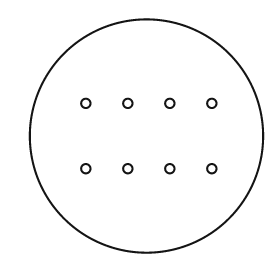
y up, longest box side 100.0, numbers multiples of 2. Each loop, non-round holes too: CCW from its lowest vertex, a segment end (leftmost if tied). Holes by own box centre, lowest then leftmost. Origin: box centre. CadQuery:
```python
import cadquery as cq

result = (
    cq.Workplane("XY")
    .moveTo(0.0, 0.0)
    .circle(50.0)
    .moveTo(-26.0, -14.0)
    .circle(2.0)
    .moveTo(-8.0, -14.0)
    .circle(2.0)
    .moveTo(10.0, -14.0)
    .circle(2.0)
    .moveTo(28.0, -14.0)
    .circle(2.0)
    .moveTo(-26.0, 14.0)
    .circle(2.0)
    .moveTo(-8.0, 14.0)
    .circle(2.0)
    .moveTo(10.0, 14.0)
    .circle(2.0)
    .moveTo(28.0, 14.0)
    .circle(2.0)
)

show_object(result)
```